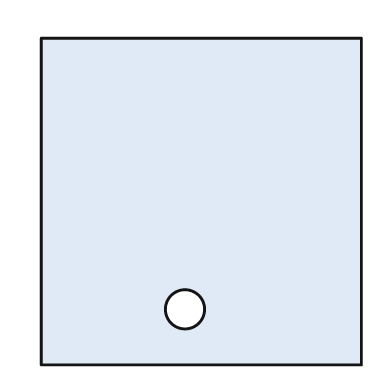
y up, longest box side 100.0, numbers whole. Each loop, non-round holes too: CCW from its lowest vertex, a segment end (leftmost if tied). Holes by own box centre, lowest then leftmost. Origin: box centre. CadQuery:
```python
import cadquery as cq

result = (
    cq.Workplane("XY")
    .moveTo(-49.0, -50.0)
    .lineTo(49.0, -50.0)
    .lineTo(49.0, 50.0)
    .lineTo(-49.0, 50.0)
    .close()
    .moveTo(-5.0, -33.0)
    .circle(6.0)
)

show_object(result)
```